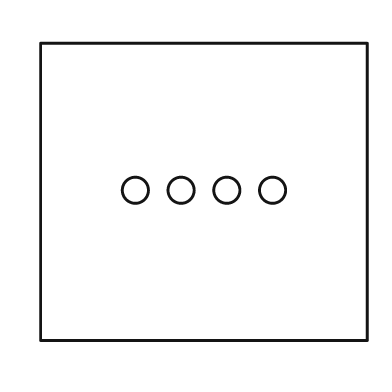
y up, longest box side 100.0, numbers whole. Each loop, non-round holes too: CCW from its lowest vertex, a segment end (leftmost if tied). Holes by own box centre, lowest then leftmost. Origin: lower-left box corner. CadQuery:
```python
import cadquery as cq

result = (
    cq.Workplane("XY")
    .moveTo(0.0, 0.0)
    .lineTo(100.0, 0.0)
    .lineTo(100.0, 91.0)
    .lineTo(0.0, 91.0)
    .close()
    .moveTo(29.0, 46.0)
    .circle(4.0)
    .moveTo(43.0, 46.0)
    .circle(4.0)
    .moveTo(57.0, 46.0)
    .circle(4.0)
    .moveTo(71.0, 46.0)
    .circle(4.0)
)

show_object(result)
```